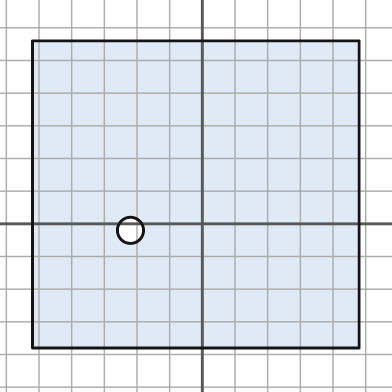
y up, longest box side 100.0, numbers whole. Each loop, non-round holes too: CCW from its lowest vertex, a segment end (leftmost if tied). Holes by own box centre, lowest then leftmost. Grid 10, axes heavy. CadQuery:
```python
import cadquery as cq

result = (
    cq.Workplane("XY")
    .moveTo(-52.0, -38.0)
    .lineTo(48.0, -38.0)
    .lineTo(48.0, 56.0)
    .lineTo(-52.0, 56.0)
    .close()
    .moveTo(-22.0, -2.0)
    .circle(4.0)
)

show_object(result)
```